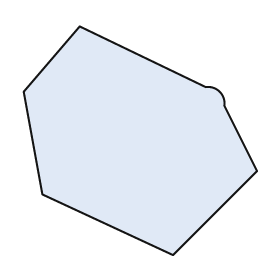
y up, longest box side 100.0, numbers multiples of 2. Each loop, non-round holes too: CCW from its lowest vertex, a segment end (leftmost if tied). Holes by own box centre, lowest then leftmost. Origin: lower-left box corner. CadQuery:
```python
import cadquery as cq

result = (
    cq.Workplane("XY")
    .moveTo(64.0, 0.0)
    .lineTo(100.0, 36.0)
    .lineTo(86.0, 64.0)
    .threePointArc((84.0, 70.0), (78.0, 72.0))
    .lineTo(24.0, 98.0)
    .lineTo(0.0, 70.0)
    .lineTo(8.0, 26.0)
    .close()
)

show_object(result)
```